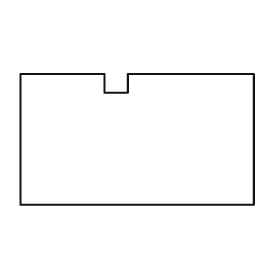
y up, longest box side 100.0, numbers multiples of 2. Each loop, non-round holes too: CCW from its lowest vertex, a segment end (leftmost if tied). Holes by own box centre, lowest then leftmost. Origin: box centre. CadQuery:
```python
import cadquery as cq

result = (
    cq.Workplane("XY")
    .moveTo(-50.0, -28.0)
    .lineTo(50.0, -28.0)
    .lineTo(50.0, 28.0)
    .lineTo(-4.0, 28.0)
    .lineTo(-4.0, 20.0)
    .lineTo(-14.0, 20.0)
    .lineTo(-14.0, 28.0)
    .lineTo(-50.0, 28.0)
    .close()
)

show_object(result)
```